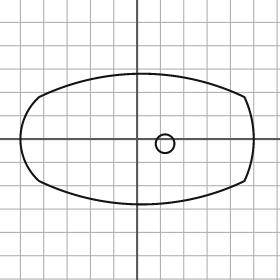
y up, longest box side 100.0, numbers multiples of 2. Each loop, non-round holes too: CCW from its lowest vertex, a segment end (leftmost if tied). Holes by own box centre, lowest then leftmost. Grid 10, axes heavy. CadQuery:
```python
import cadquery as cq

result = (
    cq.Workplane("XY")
    .moveTo(-42.0, -18.0)
    .threePointArc((2.0, -28.0), (46.0, -18.0))
    .threePointArc((50.0, 0.0), (46.0, 18.0))
    .threePointArc((2.0, 28.0), (-42.0, 18.0))
    .threePointArc((-50.0, 0.0), (-42.0, -18.0))
    .close()
    .moveTo(12.0, -2.0)
    .circle(4.0)
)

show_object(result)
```